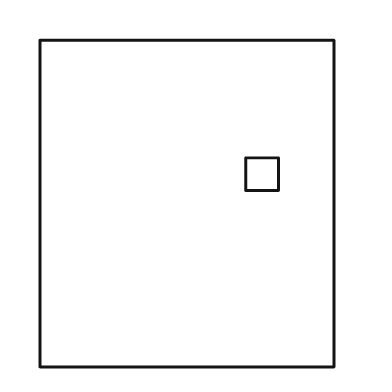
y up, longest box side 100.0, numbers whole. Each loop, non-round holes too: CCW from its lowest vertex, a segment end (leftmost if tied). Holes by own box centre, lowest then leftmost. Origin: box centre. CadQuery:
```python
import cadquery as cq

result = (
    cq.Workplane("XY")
    .moveTo(-45.0, -50.0)
    .lineTo(45.0, -50.0)
    .lineTo(45.0, 50.0)
    .lineTo(-45.0, 50.0)
    .close()
    .moveTo(18.0, 4.0)
    .lineTo(28.0, 4.0)
    .lineTo(28.0, 14.0)
    .lineTo(18.0, 14.0)
    .close()
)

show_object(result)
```